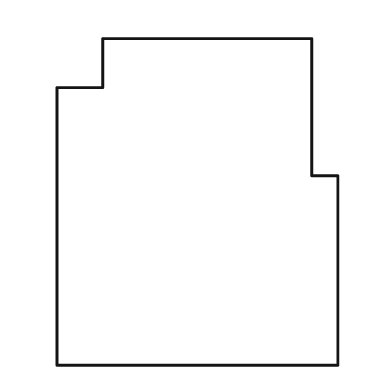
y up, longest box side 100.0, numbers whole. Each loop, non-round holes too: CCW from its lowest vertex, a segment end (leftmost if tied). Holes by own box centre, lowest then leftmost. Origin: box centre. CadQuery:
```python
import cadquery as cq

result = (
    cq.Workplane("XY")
    .moveTo(-43.0, -50.0)
    .lineTo(43.0, -50.0)
    .lineTo(43.0, 8.0)
    .lineTo(35.0, 8.0)
    .lineTo(35.0, 50.0)
    .lineTo(-29.0, 50.0)
    .lineTo(-29.0, 35.0)
    .lineTo(-43.0, 35.0)
    .close()
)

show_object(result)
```